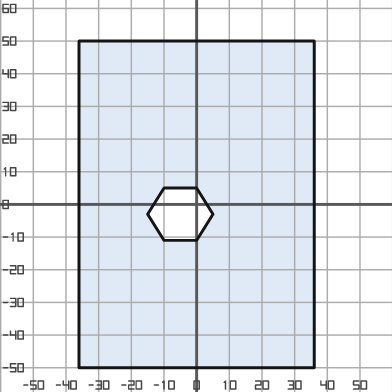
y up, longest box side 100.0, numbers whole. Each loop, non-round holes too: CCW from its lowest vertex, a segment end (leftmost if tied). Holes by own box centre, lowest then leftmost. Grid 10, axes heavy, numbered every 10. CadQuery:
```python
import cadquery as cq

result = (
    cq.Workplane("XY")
    .moveTo(-36.0, -50.0)
    .lineTo(36.0, -50.0)
    .lineTo(36.0, 50.0)
    .lineTo(-36.0, 50.0)
    .close()
    .moveTo(-10.0, -11.0)
    .lineTo(0.0, -11.0)
    .lineTo(5.0, -3.0)
    .lineTo(0.0, 5.0)
    .lineTo(-10.0, 5.0)
    .lineTo(-15.0, -3.0)
    .close()
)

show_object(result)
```